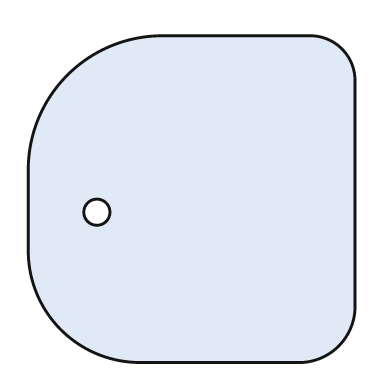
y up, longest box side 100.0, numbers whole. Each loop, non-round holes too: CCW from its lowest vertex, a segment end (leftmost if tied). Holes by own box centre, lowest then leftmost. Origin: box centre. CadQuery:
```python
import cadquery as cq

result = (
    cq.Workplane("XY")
    .moveTo(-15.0, -50.0)
    .lineTo(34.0, -50.0)
    .threePointArc((45.0, -45.0), (50.0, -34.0))
    .lineTo(50.0, 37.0)
    .threePointArc((46.0, 46.0), (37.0, 50.0))
    .lineTo(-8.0, 50.0)
    .threePointArc((-38.0, 38.0), (-50.0, 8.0))
    .lineTo(-50.0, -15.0)
    .threePointArc((-40.0, -40.0), (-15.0, -50.0))
    .close()
    .moveTo(-29.0, -4.0)
    .circle(4.0)
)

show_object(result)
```